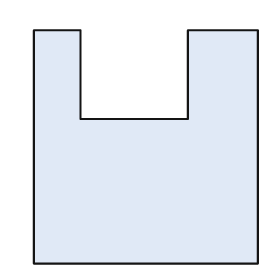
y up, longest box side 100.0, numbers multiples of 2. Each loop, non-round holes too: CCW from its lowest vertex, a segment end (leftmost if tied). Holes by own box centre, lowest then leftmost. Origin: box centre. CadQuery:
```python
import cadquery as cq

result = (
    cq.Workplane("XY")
    .moveTo(-48.0, -50.0)
    .lineTo(48.0, -50.0)
    .lineTo(48.0, 50.0)
    .lineTo(18.0, 50.0)
    .lineTo(18.0, 12.0)
    .lineTo(-28.0, 12.0)
    .lineTo(-28.0, 50.0)
    .lineTo(-48.0, 50.0)
    .close()
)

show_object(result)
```